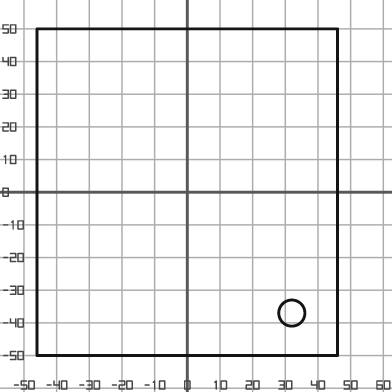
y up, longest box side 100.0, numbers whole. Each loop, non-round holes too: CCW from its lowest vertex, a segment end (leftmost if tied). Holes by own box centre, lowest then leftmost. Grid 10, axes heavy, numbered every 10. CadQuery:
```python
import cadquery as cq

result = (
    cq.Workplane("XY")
    .moveTo(-46.0, -50.0)
    .lineTo(46.0, -50.0)
    .lineTo(46.0, 50.0)
    .lineTo(-46.0, 50.0)
    .close()
    .moveTo(32.0, -37.0)
    .circle(4.0)
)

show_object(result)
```